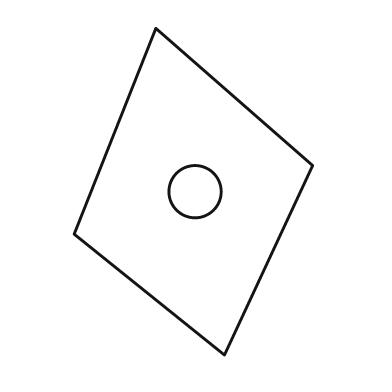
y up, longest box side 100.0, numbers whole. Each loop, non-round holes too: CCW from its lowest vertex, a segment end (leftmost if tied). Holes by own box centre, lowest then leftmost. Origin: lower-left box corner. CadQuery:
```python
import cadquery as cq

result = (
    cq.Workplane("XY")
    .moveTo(46.0, 0.0)
    .lineTo(73.0, 58.0)
    .lineTo(25.0, 100.0)
    .lineTo(0.0, 37.0)
    .close()
    .moveTo(37.0, 50.0)
    .circle(8.0)
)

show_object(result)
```